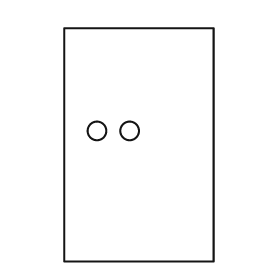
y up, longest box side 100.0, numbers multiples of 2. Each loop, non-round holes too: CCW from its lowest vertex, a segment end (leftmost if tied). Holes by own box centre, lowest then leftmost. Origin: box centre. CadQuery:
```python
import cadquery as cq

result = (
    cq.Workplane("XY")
    .moveTo(-32.0, -50.0)
    .lineTo(32.0, -50.0)
    .lineTo(32.0, 50.0)
    .lineTo(-32.0, 50.0)
    .close()
    .moveTo(-18.0, 6.0)
    .circle(4.0)
    .moveTo(-4.0, 6.0)
    .circle(4.0)
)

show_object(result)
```